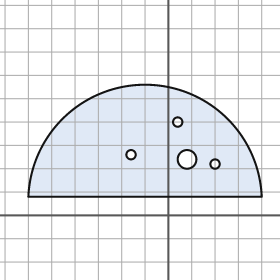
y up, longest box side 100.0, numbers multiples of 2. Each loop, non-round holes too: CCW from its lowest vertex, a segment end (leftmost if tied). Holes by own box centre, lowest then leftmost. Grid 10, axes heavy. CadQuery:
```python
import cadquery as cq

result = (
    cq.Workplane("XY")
    .moveTo(-60.0, 8.0)
    .lineTo(40.0, 8.0)
    .threePointArc((-10.0, 56.0), (-60.0, 8.0))
    .close()
    .moveTo(20.0, 22.0)
    .circle(2.0)
    .moveTo(8.0, 24.0)
    .circle(4.0)
    .moveTo(-16.0, 26.0)
    .circle(2.0)
    .moveTo(4.0, 40.0)
    .circle(2.0)
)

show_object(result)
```